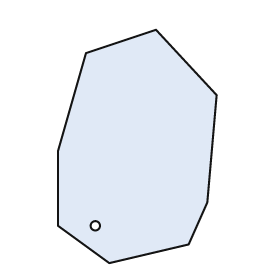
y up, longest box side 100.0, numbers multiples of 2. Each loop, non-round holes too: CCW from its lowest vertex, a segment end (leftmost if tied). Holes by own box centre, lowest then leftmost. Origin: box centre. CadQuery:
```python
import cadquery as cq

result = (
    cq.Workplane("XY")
    .moveTo(-12.0, -50.0)
    .lineTo(22.0, -42.0)
    .lineTo(30.0, -24.0)
    .lineTo(34.0, 22.0)
    .lineTo(8.0, 50.0)
    .lineTo(-22.0, 40.0)
    .lineTo(-34.0, -2.0)
    .lineTo(-34.0, -34.0)
    .close()
    .moveTo(-18.0, -34.0)
    .circle(2.0)
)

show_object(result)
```